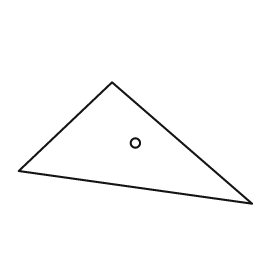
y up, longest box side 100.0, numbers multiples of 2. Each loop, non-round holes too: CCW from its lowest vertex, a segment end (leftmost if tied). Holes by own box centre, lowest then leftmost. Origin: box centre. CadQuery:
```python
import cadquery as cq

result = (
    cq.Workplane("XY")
    .moveTo(50.0, -26.0)
    .lineTo(-10.0, 26.0)
    .lineTo(-50.0, -12.0)
    .close()
    .moveTo(0.0, 0.0)
    .circle(2.0)
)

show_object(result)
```